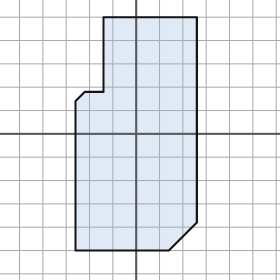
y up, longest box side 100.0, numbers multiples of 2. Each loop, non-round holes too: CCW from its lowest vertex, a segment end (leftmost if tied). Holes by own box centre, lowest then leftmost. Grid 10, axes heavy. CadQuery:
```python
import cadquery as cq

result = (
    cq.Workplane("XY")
    .moveTo(-26.0, -50.0)
    .lineTo(14.0, -50.0)
    .lineTo(26.0, -38.0)
    .lineTo(26.0, 50.0)
    .lineTo(-14.0, 50.0)
    .lineTo(-14.0, 18.0)
    .lineTo(-22.0, 18.0)
    .lineTo(-26.0, 14.0)
    .close()
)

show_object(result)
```